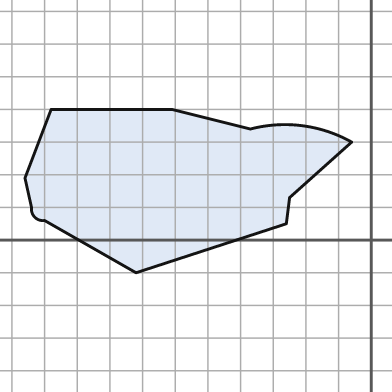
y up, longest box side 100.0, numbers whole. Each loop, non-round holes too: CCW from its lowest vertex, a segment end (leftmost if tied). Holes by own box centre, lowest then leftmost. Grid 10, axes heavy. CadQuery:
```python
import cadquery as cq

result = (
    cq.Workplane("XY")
    .moveTo(-72.0, -10.0)
    .lineTo(-26.0, 5.0)
    .lineTo(-25.0, 13.0)
    .lineTo(-6.0, 30.0)
    .threePointArc((-21.0, 35.0), (-37.0, 34.0))
    .lineTo(-61.0, 40.0)
    .lineTo(-98.0, 40.0)
    .lineTo(-106.0, 19.0)
    .lineTo(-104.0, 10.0)
    .threePointArc((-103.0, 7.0), (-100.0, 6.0))
    .close()
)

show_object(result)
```